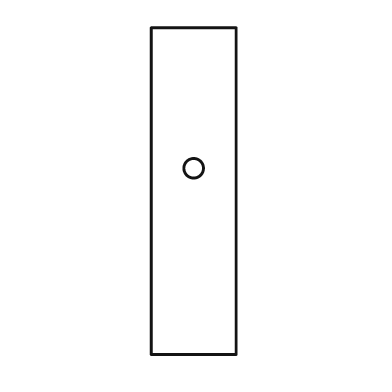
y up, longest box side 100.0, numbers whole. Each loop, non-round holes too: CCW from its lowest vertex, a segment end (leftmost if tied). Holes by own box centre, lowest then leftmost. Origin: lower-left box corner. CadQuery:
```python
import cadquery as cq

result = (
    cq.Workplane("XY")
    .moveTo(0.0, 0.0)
    .lineTo(26.0, 0.0)
    .lineTo(26.0, 100.0)
    .lineTo(0.0, 100.0)
    .close()
    .moveTo(13.0, 57.0)
    .circle(3.0)
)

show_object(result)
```